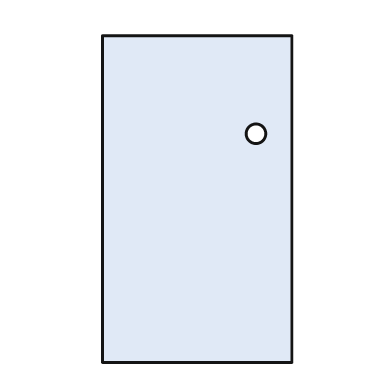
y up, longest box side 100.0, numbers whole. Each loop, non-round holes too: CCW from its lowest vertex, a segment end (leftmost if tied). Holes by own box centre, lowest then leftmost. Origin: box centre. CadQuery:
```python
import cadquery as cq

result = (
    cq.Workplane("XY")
    .moveTo(-29.0, -50.0)
    .lineTo(29.0, -50.0)
    .lineTo(29.0, 50.0)
    .lineTo(-29.0, 50.0)
    .close()
    .moveTo(18.0, 20.0)
    .circle(3.0)
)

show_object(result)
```